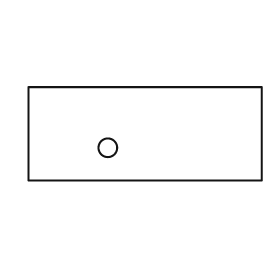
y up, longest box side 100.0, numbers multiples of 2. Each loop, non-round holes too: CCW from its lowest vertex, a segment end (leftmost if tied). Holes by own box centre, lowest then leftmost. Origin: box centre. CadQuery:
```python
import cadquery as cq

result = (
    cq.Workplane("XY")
    .moveTo(-50.0, -20.0)
    .lineTo(50.0, -20.0)
    .lineTo(50.0, 20.0)
    .lineTo(-50.0, 20.0)
    .close()
    .moveTo(-16.0, -6.0)
    .circle(4.0)
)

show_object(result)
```